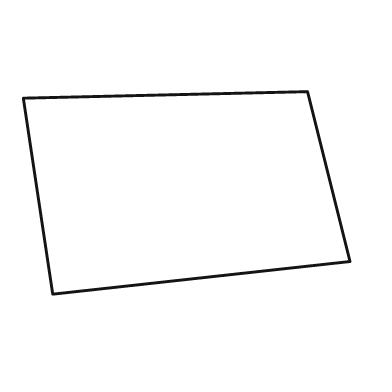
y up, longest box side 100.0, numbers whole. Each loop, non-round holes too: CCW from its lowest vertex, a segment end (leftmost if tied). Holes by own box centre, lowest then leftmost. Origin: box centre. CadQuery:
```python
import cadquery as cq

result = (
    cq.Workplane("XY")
    .moveTo(-41.0, -31.0)
    .lineTo(50.0, -21.0)
    .lineTo(37.0, 31.0)
    .lineTo(-50.0, 29.0)
    .close()
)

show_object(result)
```